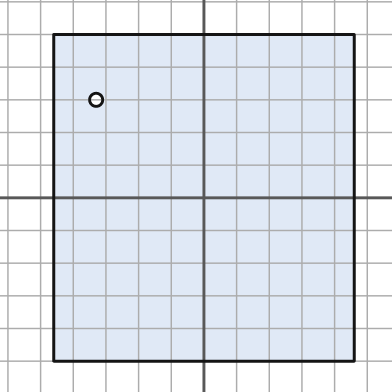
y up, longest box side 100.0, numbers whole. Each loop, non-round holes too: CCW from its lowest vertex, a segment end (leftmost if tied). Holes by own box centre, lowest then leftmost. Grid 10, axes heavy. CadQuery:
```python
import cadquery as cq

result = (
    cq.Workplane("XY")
    .moveTo(-46.0, -50.0)
    .lineTo(46.0, -50.0)
    .lineTo(46.0, 50.0)
    .lineTo(-46.0, 50.0)
    .close()
    .moveTo(-33.0, 30.0)
    .circle(2.0)
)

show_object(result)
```